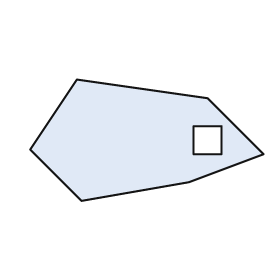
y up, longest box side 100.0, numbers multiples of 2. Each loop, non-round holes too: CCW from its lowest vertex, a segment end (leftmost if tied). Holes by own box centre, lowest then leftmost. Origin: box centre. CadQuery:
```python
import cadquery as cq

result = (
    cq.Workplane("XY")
    .moveTo(-28.0, -26.0)
    .lineTo(18.0, -18.0)
    .lineTo(50.0, -6.0)
    .lineTo(26.0, 18.0)
    .lineTo(-30.0, 26.0)
    .lineTo(-50.0, -4.0)
    .close()
    .moveTo(20.0, -6.0)
    .lineTo(32.0, -6.0)
    .lineTo(32.0, 6.0)
    .lineTo(20.0, 6.0)
    .close()
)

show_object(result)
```